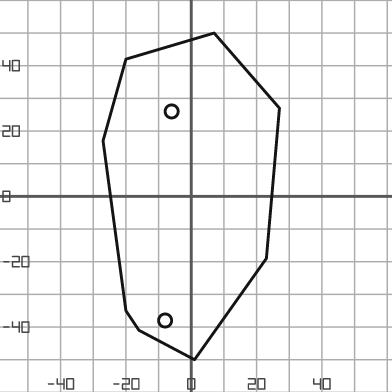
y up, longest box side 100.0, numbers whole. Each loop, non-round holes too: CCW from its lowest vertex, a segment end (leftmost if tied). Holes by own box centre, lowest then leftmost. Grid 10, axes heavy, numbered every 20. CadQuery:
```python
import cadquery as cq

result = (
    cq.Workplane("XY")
    .moveTo(1.0, -50.0)
    .lineTo(23.0, -19.0)
    .lineTo(27.0, 27.0)
    .lineTo(7.0, 50.0)
    .lineTo(-20.0, 42.0)
    .lineTo(-27.0, 17.0)
    .lineTo(-20.0, -35.0)
    .lineTo(-16.0, -41.0)
    .close()
    .moveTo(-8.0, -38.0)
    .circle(2.0)
    .moveTo(-6.0, 26.0)
    .circle(2.0)
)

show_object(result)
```